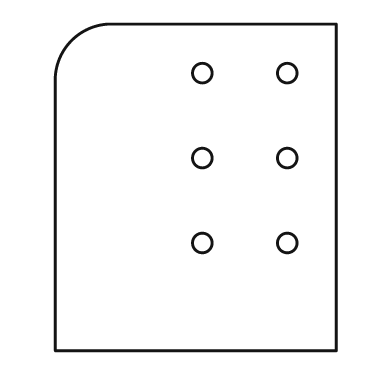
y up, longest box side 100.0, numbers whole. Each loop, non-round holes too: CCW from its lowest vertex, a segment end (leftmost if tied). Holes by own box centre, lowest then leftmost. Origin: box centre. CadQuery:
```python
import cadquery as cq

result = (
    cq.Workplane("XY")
    .moveTo(-43.0, -50.0)
    .lineTo(43.0, -50.0)
    .lineTo(43.0, 50.0)
    .lineTo(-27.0, 50.0)
    .threePointArc((-38.0, 45.0), (-43.0, 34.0))
    .close()
    .moveTo(2.0, -17.0)
    .circle(3.0)
    .moveTo(28.0, -17.0)
    .circle(3.0)
    .moveTo(2.0, 9.0)
    .circle(3.0)
    .moveTo(28.0, 9.0)
    .circle(3.0)
    .moveTo(2.0, 35.0)
    .circle(3.0)
    .moveTo(28.0, 35.0)
    .circle(3.0)
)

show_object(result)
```